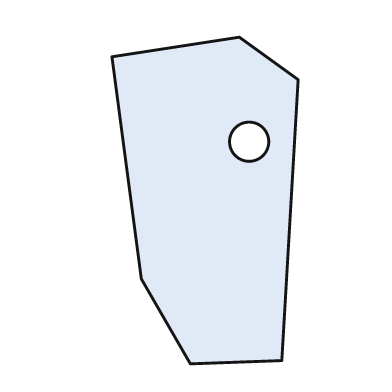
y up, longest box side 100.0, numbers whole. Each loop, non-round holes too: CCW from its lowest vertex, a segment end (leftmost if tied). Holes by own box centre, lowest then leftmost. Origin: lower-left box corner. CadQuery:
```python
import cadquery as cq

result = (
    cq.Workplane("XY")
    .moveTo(24.0, 0.0)
    .lineTo(52.0, 1.0)
    .lineTo(57.0, 87.0)
    .lineTo(39.0, 100.0)
    .lineTo(0.0, 94.0)
    .lineTo(9.0, 26.0)
    .close()
    .moveTo(42.0, 68.0)
    .circle(6.0)
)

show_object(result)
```